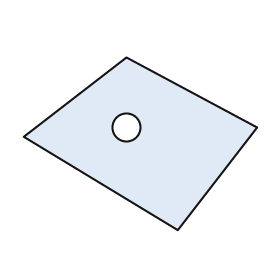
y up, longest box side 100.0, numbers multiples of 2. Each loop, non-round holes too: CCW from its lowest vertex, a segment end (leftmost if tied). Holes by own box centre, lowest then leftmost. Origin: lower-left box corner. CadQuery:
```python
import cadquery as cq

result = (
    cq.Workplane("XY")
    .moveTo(66.0, 0.0)
    .lineTo(100.0, 44.0)
    .lineTo(44.0, 74.0)
    .lineTo(0.0, 40.0)
    .close()
    .moveTo(44.0, 44.0)
    .circle(6.0)
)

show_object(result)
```